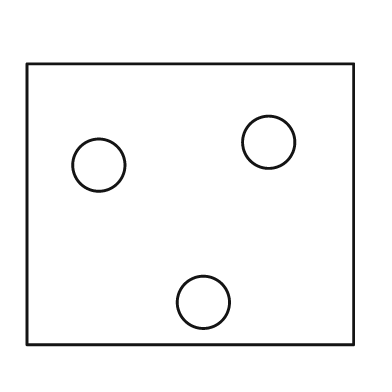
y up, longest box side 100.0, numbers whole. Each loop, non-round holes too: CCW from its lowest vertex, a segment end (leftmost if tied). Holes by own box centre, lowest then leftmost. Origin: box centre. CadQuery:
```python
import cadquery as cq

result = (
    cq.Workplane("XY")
    .moveTo(-50.0, -43.0)
    .lineTo(50.0, -43.0)
    .lineTo(50.0, 43.0)
    .lineTo(-50.0, 43.0)
    .close()
    .moveTo(4.0, -30.0)
    .circle(8.0)
    .moveTo(-28.0, 12.0)
    .circle(8.0)
    .moveTo(24.0, 19.0)
    .circle(8.0)
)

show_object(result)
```